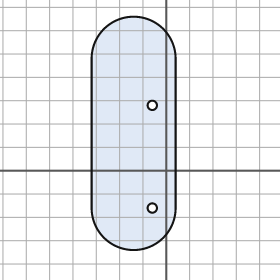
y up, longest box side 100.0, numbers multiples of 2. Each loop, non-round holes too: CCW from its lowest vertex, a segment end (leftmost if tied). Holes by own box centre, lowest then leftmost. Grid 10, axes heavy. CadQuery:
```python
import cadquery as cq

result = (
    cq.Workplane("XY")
    .moveTo(-32.0, -16.0)
    .threePointArc((-14.0, -34.0), (4.0, -16.0))
    .lineTo(4.0, 48.0)
    .threePointArc((-14.0, 66.0), (-32.0, 48.0))
    .close()
    .moveTo(-6.0, -16.0)
    .circle(2.0)
    .moveTo(-6.0, 28.0)
    .circle(2.0)
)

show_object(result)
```